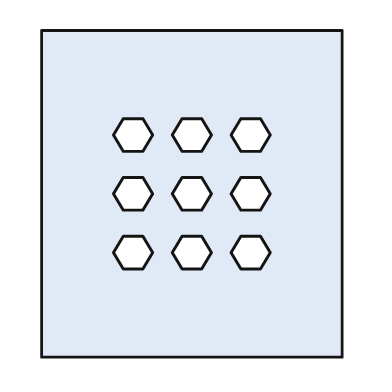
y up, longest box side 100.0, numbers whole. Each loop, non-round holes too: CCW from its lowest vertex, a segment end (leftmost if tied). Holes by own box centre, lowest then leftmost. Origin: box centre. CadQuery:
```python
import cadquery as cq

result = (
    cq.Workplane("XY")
    .moveTo(-46.0, -50.0)
    .lineTo(46.0, -50.0)
    .lineTo(46.0, 50.0)
    .lineTo(-46.0, 50.0)
    .close()
    .moveTo(-21.0, -23.0)
    .lineTo(-15.0, -23.0)
    .lineTo(-12.0, -18.0)
    .lineTo(-15.0, -13.0)
    .lineTo(-21.0, -13.0)
    .lineTo(-24.0, -18.0)
    .close()
    .moveTo(-3.0, -23.0)
    .lineTo(3.0, -23.0)
    .lineTo(6.0, -18.0)
    .lineTo(3.0, -13.0)
    .lineTo(-3.0, -13.0)
    .lineTo(-6.0, -18.0)
    .close()
    .moveTo(15.0, -23.0)
    .lineTo(21.0, -23.0)
    .lineTo(24.0, -18.0)
    .lineTo(21.0, -13.0)
    .lineTo(15.0, -13.0)
    .lineTo(12.0, -18.0)
    .close()
    .moveTo(-21.0, -5.0)
    .lineTo(-15.0, -5.0)
    .lineTo(-12.0, 0.0)
    .lineTo(-15.0, 5.0)
    .lineTo(-21.0, 5.0)
    .lineTo(-24.0, 0.0)
    .close()
    .moveTo(-3.0, -5.0)
    .lineTo(3.0, -5.0)
    .lineTo(6.0, 0.0)
    .lineTo(3.0, 5.0)
    .lineTo(-3.0, 5.0)
    .lineTo(-6.0, 0.0)
    .close()
    .moveTo(15.0, -5.0)
    .lineTo(21.0, -5.0)
    .lineTo(24.0, 0.0)
    .lineTo(21.0, 5.0)
    .lineTo(15.0, 5.0)
    .lineTo(12.0, 0.0)
    .close()
    .moveTo(-21.0, 13.0)
    .lineTo(-15.0, 13.0)
    .lineTo(-12.0, 18.0)
    .lineTo(-15.0, 23.0)
    .lineTo(-21.0, 23.0)
    .lineTo(-24.0, 18.0)
    .close()
    .moveTo(-3.0, 13.0)
    .lineTo(3.0, 13.0)
    .lineTo(6.0, 18.0)
    .lineTo(3.0, 23.0)
    .lineTo(-3.0, 23.0)
    .lineTo(-6.0, 18.0)
    .close()
    .moveTo(15.0, 13.0)
    .lineTo(21.0, 13.0)
    .lineTo(24.0, 18.0)
    .lineTo(21.0, 23.0)
    .lineTo(15.0, 23.0)
    .lineTo(12.0, 18.0)
    .close()
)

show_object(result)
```